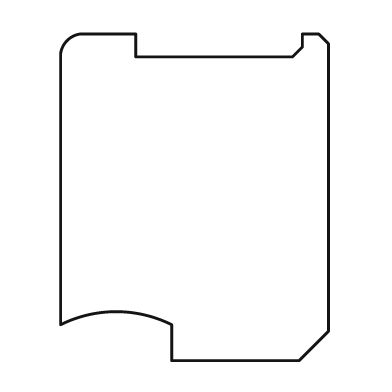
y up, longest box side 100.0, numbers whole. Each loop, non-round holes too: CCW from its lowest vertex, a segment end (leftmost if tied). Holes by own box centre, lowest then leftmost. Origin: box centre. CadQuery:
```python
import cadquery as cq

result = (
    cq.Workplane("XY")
    .moveTo(-7.0, -50.0)
    .lineTo(32.0, -50.0)
    .lineTo(41.0, -41.0)
    .lineTo(41.0, 47.0)
    .lineTo(38.0, 50.0)
    .lineTo(33.0, 50.0)
    .lineTo(33.0, 46.0)
    .lineTo(30.0, 43.0)
    .lineTo(-18.0, 43.0)
    .lineTo(-18.0, 50.0)
    .lineTo(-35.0, 50.0)
    .threePointArc((-39.0, 48.0), (-41.0, 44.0))
    .lineTo(-41.0, -39.0)
    .threePointArc((-24.0, -35.0), (-7.0, -39.0))
    .close()
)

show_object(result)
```